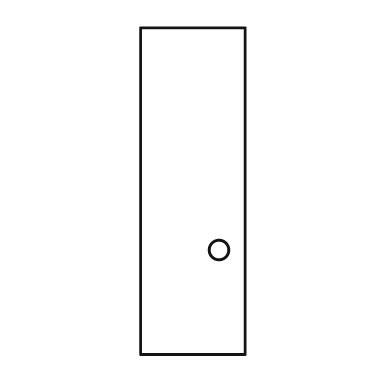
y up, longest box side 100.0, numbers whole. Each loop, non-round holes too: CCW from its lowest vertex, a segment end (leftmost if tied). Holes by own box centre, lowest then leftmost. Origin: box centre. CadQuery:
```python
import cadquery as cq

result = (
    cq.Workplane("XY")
    .moveTo(-16.0, -50.0)
    .lineTo(16.0, -50.0)
    .lineTo(16.0, 50.0)
    .lineTo(-16.0, 50.0)
    .close()
    .moveTo(8.0, -18.0)
    .circle(3.0)
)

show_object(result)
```